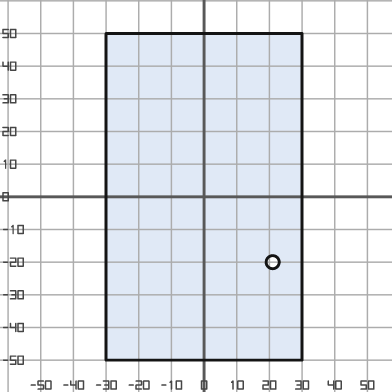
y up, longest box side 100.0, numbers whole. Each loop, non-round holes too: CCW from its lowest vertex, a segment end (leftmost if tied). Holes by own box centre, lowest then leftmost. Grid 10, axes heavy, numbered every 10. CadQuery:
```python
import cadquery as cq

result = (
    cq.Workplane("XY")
    .moveTo(-30.0, -50.0)
    .lineTo(30.0, -50.0)
    .lineTo(30.0, 50.0)
    .lineTo(-30.0, 50.0)
    .close()
    .moveTo(21.0, -20.0)
    .circle(2.0)
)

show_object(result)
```